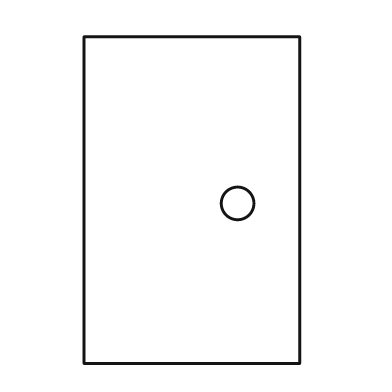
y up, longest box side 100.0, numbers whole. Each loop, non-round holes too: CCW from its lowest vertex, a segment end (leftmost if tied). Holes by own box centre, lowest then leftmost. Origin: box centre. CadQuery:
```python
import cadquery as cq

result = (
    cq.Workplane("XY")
    .moveTo(-33.0, -50.0)
    .lineTo(33.0, -50.0)
    .lineTo(33.0, 50.0)
    .lineTo(-33.0, 50.0)
    .close()
    .moveTo(14.0, -1.0)
    .circle(5.0)
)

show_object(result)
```